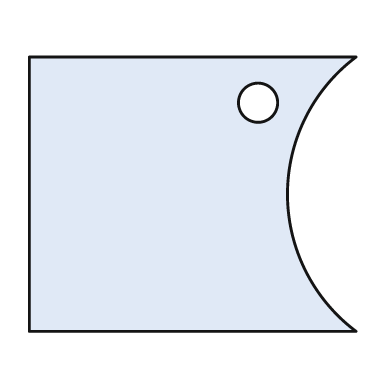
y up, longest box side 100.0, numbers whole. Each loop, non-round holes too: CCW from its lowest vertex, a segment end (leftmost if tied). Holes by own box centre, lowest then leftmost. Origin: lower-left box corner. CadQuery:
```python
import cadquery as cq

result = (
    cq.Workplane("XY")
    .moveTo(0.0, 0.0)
    .lineTo(100.0, 0.0)
    .threePointArc((79.0, 42.0), (100.0, 84.0))
    .lineTo(0.0, 84.0)
    .close()
    .moveTo(70.0, 70.0)
    .circle(6.0)
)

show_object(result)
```